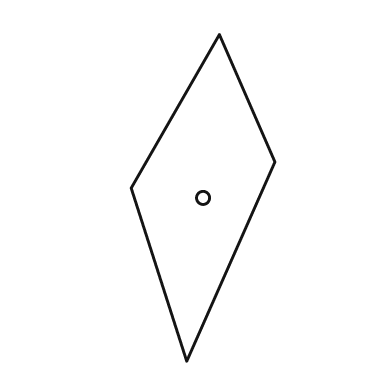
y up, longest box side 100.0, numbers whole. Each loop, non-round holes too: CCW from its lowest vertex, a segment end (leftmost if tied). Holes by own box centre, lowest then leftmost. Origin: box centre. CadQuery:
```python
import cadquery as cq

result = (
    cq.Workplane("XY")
    .moveTo(-5.0, -50.0)
    .lineTo(22.0, 11.0)
    .lineTo(5.0, 50.0)
    .lineTo(-22.0, 3.0)
    .close()
    .moveTo(0.0, 0.0)
    .circle(2.0)
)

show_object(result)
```